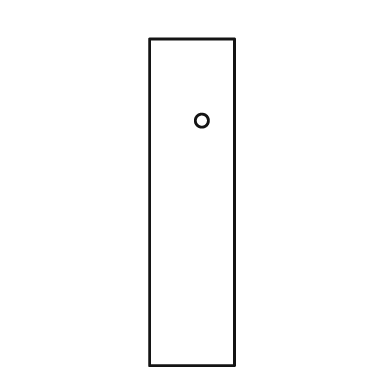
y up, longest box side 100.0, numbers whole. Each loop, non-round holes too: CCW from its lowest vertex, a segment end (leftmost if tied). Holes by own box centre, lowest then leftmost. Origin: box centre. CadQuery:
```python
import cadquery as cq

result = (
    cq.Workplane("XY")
    .moveTo(-13.0, -50.0)
    .lineTo(13.0, -50.0)
    .lineTo(13.0, 50.0)
    .lineTo(-13.0, 50.0)
    .close()
    .moveTo(3.0, 25.0)
    .circle(2.0)
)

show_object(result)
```